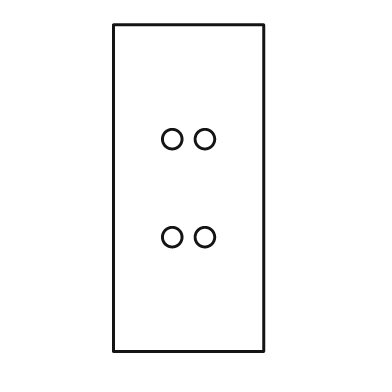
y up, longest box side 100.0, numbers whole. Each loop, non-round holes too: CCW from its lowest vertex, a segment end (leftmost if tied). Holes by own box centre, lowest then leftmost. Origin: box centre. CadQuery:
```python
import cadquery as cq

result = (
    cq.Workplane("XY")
    .moveTo(-23.0, -50.0)
    .lineTo(23.0, -50.0)
    .lineTo(23.0, 50.0)
    .lineTo(-23.0, 50.0)
    .close()
    .moveTo(-5.0, -15.0)
    .circle(3.0)
    .moveTo(5.0, -15.0)
    .circle(3.0)
    .moveTo(-5.0, 15.0)
    .circle(3.0)
    .moveTo(5.0, 15.0)
    .circle(3.0)
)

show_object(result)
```